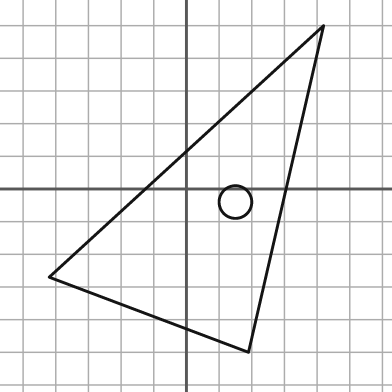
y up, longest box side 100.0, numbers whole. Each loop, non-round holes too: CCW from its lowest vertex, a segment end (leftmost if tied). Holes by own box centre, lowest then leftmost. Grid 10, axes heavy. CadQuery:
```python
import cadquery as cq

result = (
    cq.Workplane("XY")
    .moveTo(19.0, -50.0)
    .lineTo(42.0, 50.0)
    .lineTo(-42.0, -27.0)
    .close()
    .moveTo(15.0, -4.0)
    .circle(5.0)
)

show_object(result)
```